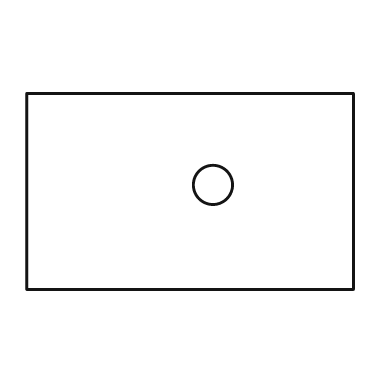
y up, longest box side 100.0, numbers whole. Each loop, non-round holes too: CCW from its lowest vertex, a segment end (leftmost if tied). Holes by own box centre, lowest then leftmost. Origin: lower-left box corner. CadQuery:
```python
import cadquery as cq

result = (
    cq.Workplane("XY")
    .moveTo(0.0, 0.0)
    .lineTo(100.0, 0.0)
    .lineTo(100.0, 60.0)
    .lineTo(0.0, 60.0)
    .close()
    .moveTo(57.0, 32.0)
    .circle(6.0)
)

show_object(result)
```